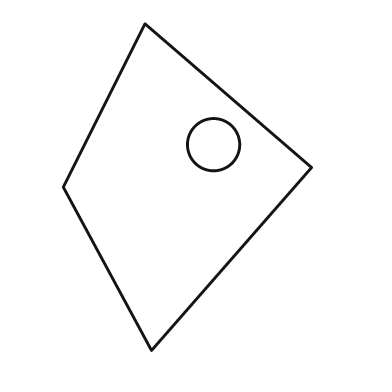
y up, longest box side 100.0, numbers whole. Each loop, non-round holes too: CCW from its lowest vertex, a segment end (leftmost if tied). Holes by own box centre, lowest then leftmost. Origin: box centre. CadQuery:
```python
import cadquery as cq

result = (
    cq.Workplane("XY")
    .moveTo(-11.0, -50.0)
    .lineTo(38.0, 6.0)
    .lineTo(-13.0, 50.0)
    .lineTo(-38.0, 0.0)
    .close()
    .moveTo(8.0, 13.0)
    .circle(8.0)
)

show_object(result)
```